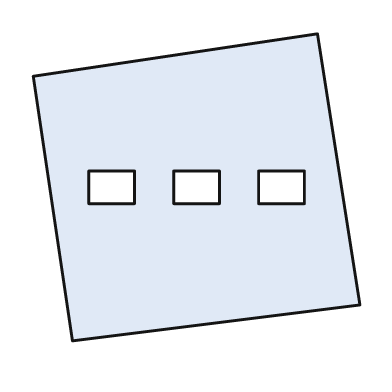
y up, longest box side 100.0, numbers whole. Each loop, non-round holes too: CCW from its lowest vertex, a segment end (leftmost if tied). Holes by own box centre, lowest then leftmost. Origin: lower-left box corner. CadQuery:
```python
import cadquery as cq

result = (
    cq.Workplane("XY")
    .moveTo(12.0, 0.0)
    .lineTo(100.0, 11.0)
    .lineTo(87.0, 94.0)
    .lineTo(0.0, 81.0)
    .close()
    .moveTo(17.0, 42.0)
    .lineTo(31.0, 42.0)
    .lineTo(31.0, 52.0)
    .lineTo(17.0, 52.0)
    .close()
    .moveTo(43.0, 42.0)
    .lineTo(57.0, 42.0)
    .lineTo(57.0, 52.0)
    .lineTo(43.0, 52.0)
    .close()
    .moveTo(69.0, 42.0)
    .lineTo(83.0, 42.0)
    .lineTo(83.0, 52.0)
    .lineTo(69.0, 52.0)
    .close()
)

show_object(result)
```